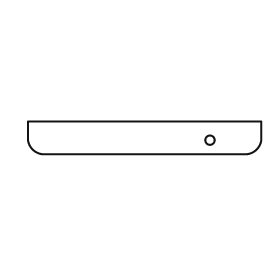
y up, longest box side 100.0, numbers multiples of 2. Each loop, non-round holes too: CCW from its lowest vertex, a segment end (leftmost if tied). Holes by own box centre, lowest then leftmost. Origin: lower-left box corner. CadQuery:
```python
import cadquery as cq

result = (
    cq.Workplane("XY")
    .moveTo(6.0, 0.0)
    .lineTo(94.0, 0.0)
    .threePointArc((98.0, 2.0), (100.0, 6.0))
    .lineTo(100.0, 14.0)
    .lineTo(0.0, 14.0)
    .lineTo(0.0, 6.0)
    .threePointArc((2.0, 2.0), (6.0, 0.0))
    .close()
    .moveTo(78.0, 6.0)
    .circle(2.0)
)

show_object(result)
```